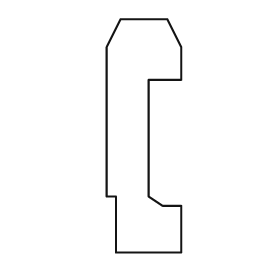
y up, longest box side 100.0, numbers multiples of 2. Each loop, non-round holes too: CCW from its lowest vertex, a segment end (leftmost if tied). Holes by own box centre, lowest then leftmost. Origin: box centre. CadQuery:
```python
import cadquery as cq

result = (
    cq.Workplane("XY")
    .moveTo(-12.0, -50.0)
    .lineTo(16.0, -50.0)
    .lineTo(16.0, -30.0)
    .lineTo(8.0, -30.0)
    .lineTo(2.0, -26.0)
    .lineTo(2.0, 24.0)
    .lineTo(16.0, 24.0)
    .lineTo(16.0, 38.0)
    .lineTo(10.0, 50.0)
    .lineTo(-10.0, 50.0)
    .lineTo(-16.0, 38.0)
    .lineTo(-16.0, -26.0)
    .lineTo(-12.0, -26.0)
    .close()
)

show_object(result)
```